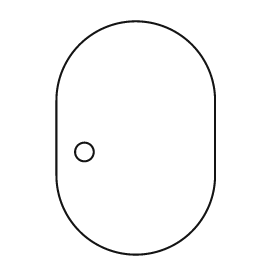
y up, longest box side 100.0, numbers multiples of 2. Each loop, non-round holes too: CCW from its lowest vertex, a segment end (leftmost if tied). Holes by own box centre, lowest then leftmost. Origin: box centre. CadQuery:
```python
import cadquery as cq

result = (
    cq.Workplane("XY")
    .moveTo(-34.0, -16.0)
    .threePointArc((0.0, -50.0), (34.0, -16.0))
    .lineTo(34.0, 16.0)
    .threePointArc((0.0, 50.0), (-34.0, 16.0))
    .close()
    .moveTo(-22.0, -6.0)
    .circle(4.0)
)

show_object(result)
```